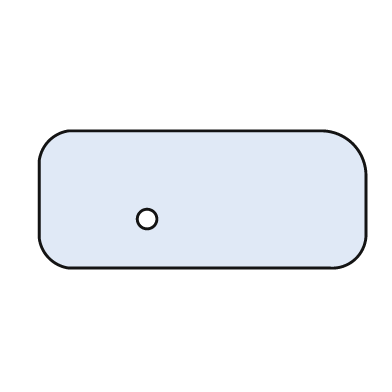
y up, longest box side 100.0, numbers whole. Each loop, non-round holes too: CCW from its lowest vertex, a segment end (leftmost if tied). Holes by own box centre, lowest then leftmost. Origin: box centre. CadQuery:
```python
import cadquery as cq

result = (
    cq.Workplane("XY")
    .moveTo(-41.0, -21.0)
    .lineTo(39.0, -21.0)
    .threePointArc((47.0, -18.0), (50.0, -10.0))
    .lineTo(50.0, 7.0)
    .threePointArc((46.0, 17.0), (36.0, 21.0))
    .lineTo(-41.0, 21.0)
    .threePointArc((-47.0, 18.0), (-50.0, 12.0))
    .lineTo(-50.0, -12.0)
    .threePointArc((-47.0, -18.0), (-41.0, -21.0))
    .close()
    .moveTo(-17.0, -6.0)
    .circle(3.0)
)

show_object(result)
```